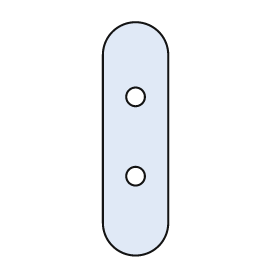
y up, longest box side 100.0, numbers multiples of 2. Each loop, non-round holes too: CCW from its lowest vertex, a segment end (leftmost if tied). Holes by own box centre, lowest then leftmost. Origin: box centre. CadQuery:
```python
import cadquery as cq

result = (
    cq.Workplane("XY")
    .moveTo(-14.0, -36.0)
    .threePointArc((0.0, -50.0), (14.0, -36.0))
    .lineTo(14.0, 36.0)
    .threePointArc((0.0, 50.0), (-14.0, 36.0))
    .close()
    .moveTo(0.0, -16.0)
    .circle(4.0)
    .moveTo(0.0, 18.0)
    .circle(4.0)
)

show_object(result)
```